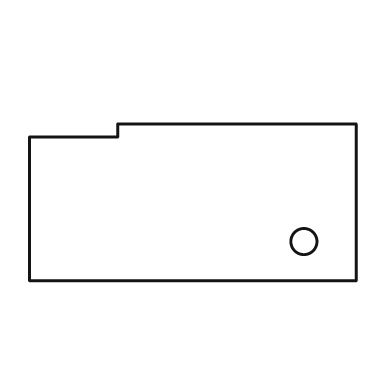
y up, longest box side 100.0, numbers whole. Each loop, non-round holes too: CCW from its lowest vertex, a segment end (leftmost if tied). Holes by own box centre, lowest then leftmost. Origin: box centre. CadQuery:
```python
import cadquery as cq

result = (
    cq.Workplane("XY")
    .moveTo(-50.0, -24.0)
    .lineTo(50.0, -24.0)
    .lineTo(50.0, 24.0)
    .lineTo(-23.0, 24.0)
    .lineTo(-23.0, 20.0)
    .lineTo(-50.0, 20.0)
    .close()
    .moveTo(34.0, -12.0)
    .circle(4.0)
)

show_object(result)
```